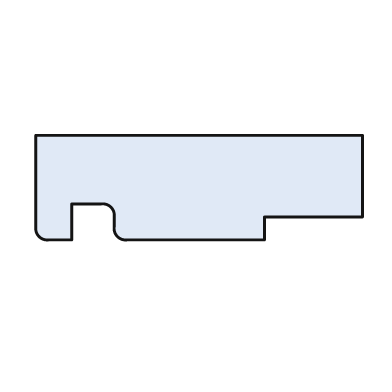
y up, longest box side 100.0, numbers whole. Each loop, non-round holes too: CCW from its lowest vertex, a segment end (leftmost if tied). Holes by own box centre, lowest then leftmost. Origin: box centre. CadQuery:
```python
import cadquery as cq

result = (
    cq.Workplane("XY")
    .moveTo(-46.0, -16.0)
    .lineTo(-39.0, -16.0)
    .lineTo(-39.0, -5.0)
    .lineTo(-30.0, -5.0)
    .threePointArc((-27.0, -6.0), (-26.0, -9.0))
    .lineTo(-26.0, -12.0)
    .threePointArc((-25.0, -15.0), (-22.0, -16.0))
    .lineTo(20.0, -16.0)
    .lineTo(20.0, -9.0)
    .lineTo(50.0, -9.0)
    .lineTo(50.0, 16.0)
    .lineTo(-50.0, 16.0)
    .lineTo(-50.0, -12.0)
    .threePointArc((-49.0, -15.0), (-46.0, -16.0))
    .close()
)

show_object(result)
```